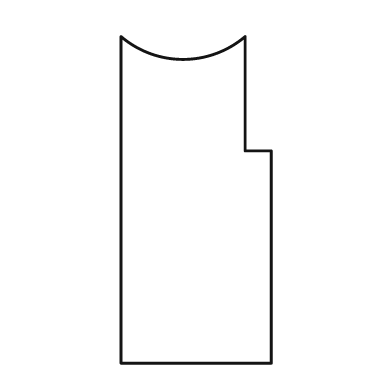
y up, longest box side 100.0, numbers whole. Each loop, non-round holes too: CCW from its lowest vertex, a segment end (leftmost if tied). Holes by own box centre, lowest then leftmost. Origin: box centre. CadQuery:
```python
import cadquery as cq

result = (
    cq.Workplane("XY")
    .moveTo(-23.0, -50.0)
    .lineTo(23.0, -50.0)
    .lineTo(23.0, 15.0)
    .lineTo(15.0, 15.0)
    .lineTo(15.0, 50.0)
    .threePointArc((-4.0, 43.0), (-23.0, 50.0))
    .close()
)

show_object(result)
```